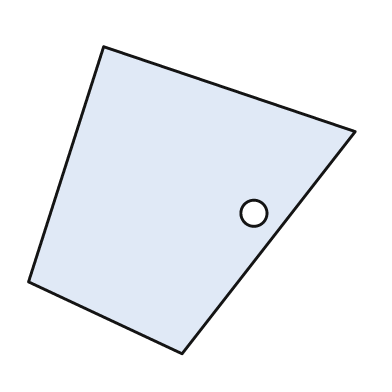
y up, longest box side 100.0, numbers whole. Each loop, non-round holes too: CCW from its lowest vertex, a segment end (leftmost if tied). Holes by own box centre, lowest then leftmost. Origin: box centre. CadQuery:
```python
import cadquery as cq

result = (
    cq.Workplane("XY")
    .moveTo(-3.0, -47.0)
    .lineTo(50.0, 21.0)
    .lineTo(-27.0, 47.0)
    .lineTo(-50.0, -25.0)
    .close()
    .moveTo(19.0, -4.0)
    .circle(4.0)
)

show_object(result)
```